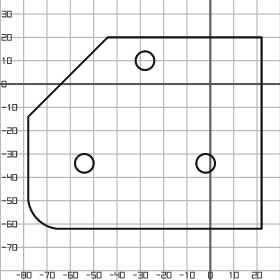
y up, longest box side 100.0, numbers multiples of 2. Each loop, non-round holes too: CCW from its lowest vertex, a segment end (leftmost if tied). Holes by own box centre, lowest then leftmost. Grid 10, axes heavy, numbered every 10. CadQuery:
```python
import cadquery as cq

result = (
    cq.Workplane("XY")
    .moveTo(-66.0, -62.0)
    .lineTo(22.0, -62.0)
    .lineTo(22.0, 20.0)
    .lineTo(-44.0, 20.0)
    .lineTo(-78.0, -14.0)
    .lineTo(-78.0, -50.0)
    .threePointArc((-74.0, -58.0), (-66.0, -62.0))
    .close()
    .moveTo(-54.0, -34.0)
    .circle(4.0)
    .moveTo(-2.0, -34.0)
    .circle(4.0)
    .moveTo(-28.0, 10.0)
    .circle(4.0)
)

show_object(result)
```